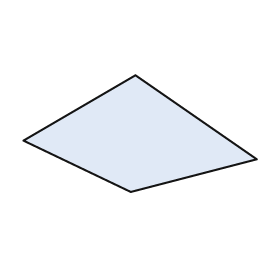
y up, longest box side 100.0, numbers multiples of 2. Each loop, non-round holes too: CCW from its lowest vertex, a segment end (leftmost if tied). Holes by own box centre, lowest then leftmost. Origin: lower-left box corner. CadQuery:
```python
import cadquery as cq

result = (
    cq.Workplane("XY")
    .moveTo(46.0, 0.0)
    .lineTo(100.0, 14.0)
    .lineTo(48.0, 50.0)
    .lineTo(0.0, 22.0)
    .close()
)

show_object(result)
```